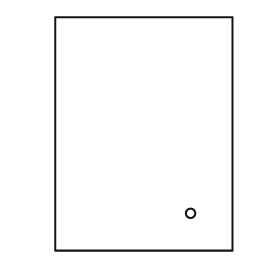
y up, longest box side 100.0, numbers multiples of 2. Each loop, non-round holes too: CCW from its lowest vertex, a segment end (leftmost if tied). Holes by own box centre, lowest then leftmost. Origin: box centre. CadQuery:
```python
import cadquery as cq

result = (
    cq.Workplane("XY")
    .moveTo(-38.0, -50.0)
    .lineTo(38.0, -50.0)
    .lineTo(38.0, 50.0)
    .lineTo(-38.0, 50.0)
    .close()
    .moveTo(20.0, -34.0)
    .circle(2.0)
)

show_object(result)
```